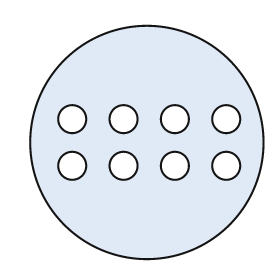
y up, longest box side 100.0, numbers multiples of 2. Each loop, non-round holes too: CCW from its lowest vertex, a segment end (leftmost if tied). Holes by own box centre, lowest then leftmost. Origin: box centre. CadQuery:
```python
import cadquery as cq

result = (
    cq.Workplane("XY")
    .moveTo(0.0, 0.0)
    .circle(50.0)
    .moveTo(-32.0, -10.0)
    .circle(6.0)
    .moveTo(-10.0, -10.0)
    .circle(6.0)
    .moveTo(12.0, -10.0)
    .circle(6.0)
    .moveTo(34.0, -10.0)
    .circle(6.0)
    .moveTo(-32.0, 10.0)
    .circle(6.0)
    .moveTo(-10.0, 10.0)
    .circle(6.0)
    .moveTo(12.0, 10.0)
    .circle(6.0)
    .moveTo(34.0, 10.0)
    .circle(6.0)
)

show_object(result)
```